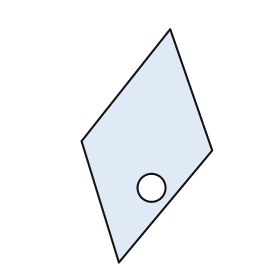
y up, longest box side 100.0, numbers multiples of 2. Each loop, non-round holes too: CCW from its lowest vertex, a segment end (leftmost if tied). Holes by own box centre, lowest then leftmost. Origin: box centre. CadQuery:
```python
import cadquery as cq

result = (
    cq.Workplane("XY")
    .moveTo(-12.0, -50.0)
    .lineTo(28.0, -2.0)
    .lineTo(10.0, 50.0)
    .lineTo(-28.0, 2.0)
    .close()
    .moveTo(2.0, -18.0)
    .circle(6.0)
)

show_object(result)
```